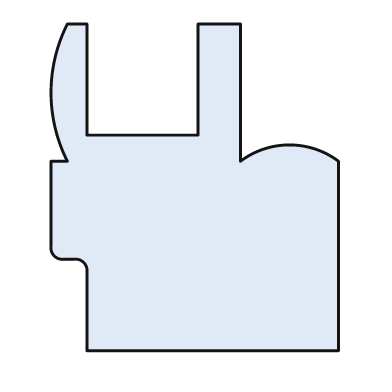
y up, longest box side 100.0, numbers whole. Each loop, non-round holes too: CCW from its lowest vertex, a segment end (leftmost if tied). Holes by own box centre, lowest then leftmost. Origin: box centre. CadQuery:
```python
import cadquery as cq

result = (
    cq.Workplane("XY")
    .moveTo(-33.0, -50.0)
    .lineTo(44.0, -50.0)
    .lineTo(44.0, 8.0)
    .threePointArc((29.0, 13.0), (14.0, 8.0))
    .lineTo(14.0, 50.0)
    .lineTo(1.0, 50.0)
    .lineTo(1.0, 16.0)
    .lineTo(-33.0, 16.0)
    .lineTo(-33.0, 50.0)
    .lineTo(-39.0, 50.0)
    .threePointArc((-44.0, 29.0), (-39.0, 8.0))
    .lineTo(-44.0, 8.0)
    .lineTo(-44.0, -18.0)
    .threePointArc((-43.0, -21.0), (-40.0, -22.0))
    .lineTo(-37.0, -22.0)
    .threePointArc((-34.0, -23.0), (-33.0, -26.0))
    .close()
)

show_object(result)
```